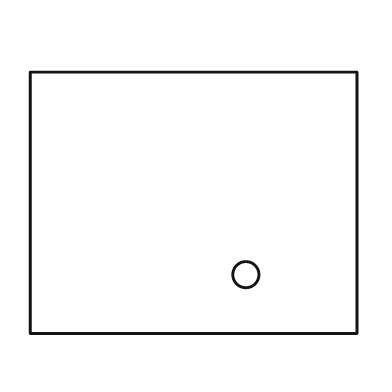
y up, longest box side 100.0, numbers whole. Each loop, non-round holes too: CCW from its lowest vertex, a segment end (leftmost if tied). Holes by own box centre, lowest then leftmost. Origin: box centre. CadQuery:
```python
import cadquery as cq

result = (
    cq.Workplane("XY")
    .moveTo(-50.0, -40.0)
    .lineTo(50.0, -40.0)
    .lineTo(50.0, 40.0)
    .lineTo(-50.0, 40.0)
    .close()
    .moveTo(16.0, -22.0)
    .circle(4.0)
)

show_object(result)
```